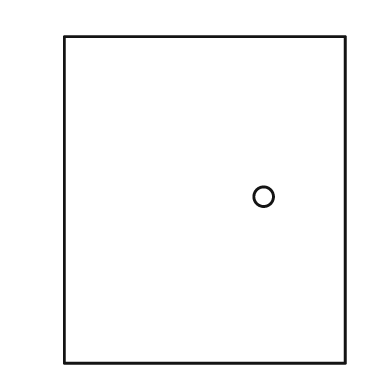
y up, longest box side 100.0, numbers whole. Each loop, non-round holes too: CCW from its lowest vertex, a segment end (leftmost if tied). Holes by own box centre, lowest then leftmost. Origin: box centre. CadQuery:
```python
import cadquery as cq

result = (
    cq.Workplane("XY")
    .moveTo(-43.0, -50.0)
    .lineTo(43.0, -50.0)
    .lineTo(43.0, 50.0)
    .lineTo(-43.0, 50.0)
    .close()
    .moveTo(18.0, 1.0)
    .circle(3.0)
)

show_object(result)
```